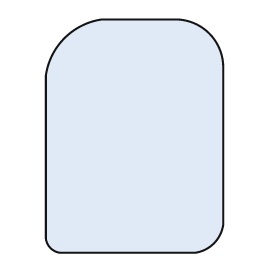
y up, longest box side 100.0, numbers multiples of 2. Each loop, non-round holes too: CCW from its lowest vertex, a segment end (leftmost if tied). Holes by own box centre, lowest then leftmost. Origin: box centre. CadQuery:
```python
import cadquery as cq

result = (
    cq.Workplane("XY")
    .moveTo(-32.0, -50.0)
    .lineTo(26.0, -50.0)
    .threePointArc((34.0, -46.0), (38.0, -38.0))
    .lineTo(38.0, 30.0)
    .threePointArc((32.0, 44.0), (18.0, 50.0))
    .lineTo(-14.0, 50.0)
    .threePointArc((-30.0, 42.0), (-38.0, 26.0))
    .lineTo(-38.0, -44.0)
    .threePointArc((-36.0, -48.0), (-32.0, -50.0))
    .close()
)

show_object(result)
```